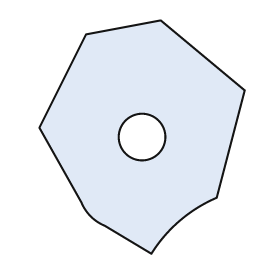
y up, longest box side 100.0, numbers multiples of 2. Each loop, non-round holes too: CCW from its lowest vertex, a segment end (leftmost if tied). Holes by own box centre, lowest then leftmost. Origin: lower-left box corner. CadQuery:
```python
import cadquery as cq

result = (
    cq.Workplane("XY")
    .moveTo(48.0, 0.0)
    .threePointArc((60.0, 14.0), (76.0, 24.0))
    .lineTo(88.0, 70.0)
    .lineTo(52.0, 100.0)
    .lineTo(20.0, 94.0)
    .lineTo(0.0, 54.0)
    .lineTo(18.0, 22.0)
    .threePointArc((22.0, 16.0), (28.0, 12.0))
    .close()
    .moveTo(44.0, 50.0)
    .circle(10.0)
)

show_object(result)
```